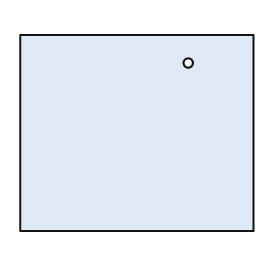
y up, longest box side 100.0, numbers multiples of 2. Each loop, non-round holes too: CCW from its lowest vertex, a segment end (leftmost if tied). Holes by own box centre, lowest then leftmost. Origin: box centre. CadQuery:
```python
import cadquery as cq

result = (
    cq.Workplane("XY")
    .moveTo(-50.0, -42.0)
    .lineTo(50.0, -42.0)
    .lineTo(50.0, 42.0)
    .lineTo(-50.0, 42.0)
    .close()
    .moveTo(22.0, 30.0)
    .circle(2.0)
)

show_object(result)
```